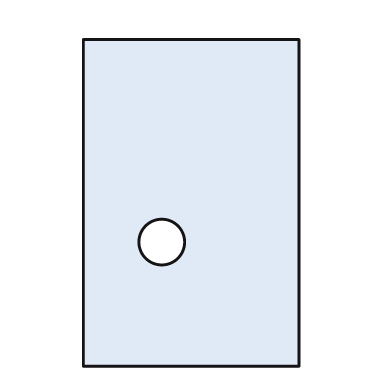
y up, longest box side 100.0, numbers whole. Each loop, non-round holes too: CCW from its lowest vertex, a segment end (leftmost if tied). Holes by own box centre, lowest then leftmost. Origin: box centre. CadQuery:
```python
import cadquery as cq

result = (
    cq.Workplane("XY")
    .moveTo(-33.0, -50.0)
    .lineTo(33.0, -50.0)
    .lineTo(33.0, 50.0)
    .lineTo(-33.0, 50.0)
    .close()
    .moveTo(-9.0, -12.0)
    .circle(7.0)
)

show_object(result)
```